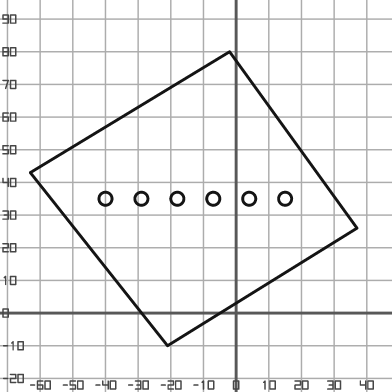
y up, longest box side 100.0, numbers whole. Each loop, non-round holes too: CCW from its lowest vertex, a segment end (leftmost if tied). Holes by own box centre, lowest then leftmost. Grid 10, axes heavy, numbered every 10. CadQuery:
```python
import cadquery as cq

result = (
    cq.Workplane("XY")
    .moveTo(-21.0, -10.0)
    .lineTo(37.0, 26.0)
    .lineTo(-2.0, 80.0)
    .lineTo(-63.0, 43.0)
    .close()
    .moveTo(-40.0, 35.0)
    .circle(2.0)
    .moveTo(-29.0, 35.0)
    .circle(2.0)
    .moveTo(-18.0, 35.0)
    .circle(2.0)
    .moveTo(-7.0, 35.0)
    .circle(2.0)
    .moveTo(4.0, 35.0)
    .circle(2.0)
    .moveTo(15.0, 35.0)
    .circle(2.0)
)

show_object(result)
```